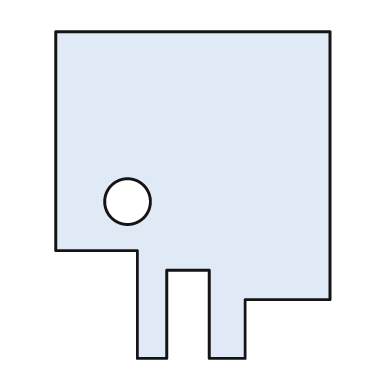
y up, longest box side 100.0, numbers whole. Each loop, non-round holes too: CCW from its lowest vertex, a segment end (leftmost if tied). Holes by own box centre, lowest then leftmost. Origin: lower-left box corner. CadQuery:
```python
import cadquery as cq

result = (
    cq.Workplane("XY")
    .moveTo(25.0, 0.0)
    .lineTo(34.0, 0.0)
    .lineTo(34.0, 27.0)
    .lineTo(47.0, 27.0)
    .lineTo(47.0, 0.0)
    .lineTo(58.0, 0.0)
    .lineTo(58.0, 18.0)
    .lineTo(84.0, 18.0)
    .lineTo(84.0, 100.0)
    .lineTo(0.0, 100.0)
    .lineTo(0.0, 33.0)
    .lineTo(25.0, 33.0)
    .close()
    .moveTo(22.0, 48.0)
    .circle(7.0)
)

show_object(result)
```